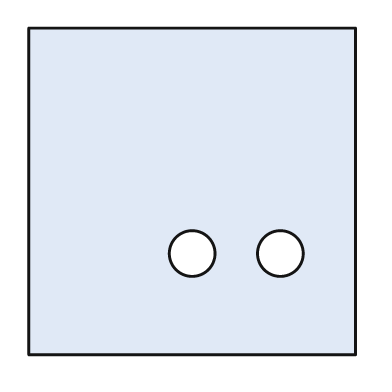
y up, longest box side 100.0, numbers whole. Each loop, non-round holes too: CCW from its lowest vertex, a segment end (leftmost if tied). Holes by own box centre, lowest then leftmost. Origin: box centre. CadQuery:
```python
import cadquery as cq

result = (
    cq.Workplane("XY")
    .moveTo(-50.0, -50.0)
    .lineTo(50.0, -50.0)
    .lineTo(50.0, 50.0)
    .lineTo(-50.0, 50.0)
    .close()
    .moveTo(0.0, -19.0)
    .circle(7.0)
    .moveTo(27.0, -19.0)
    .circle(7.0)
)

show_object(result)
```